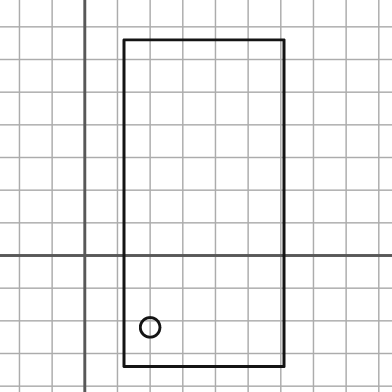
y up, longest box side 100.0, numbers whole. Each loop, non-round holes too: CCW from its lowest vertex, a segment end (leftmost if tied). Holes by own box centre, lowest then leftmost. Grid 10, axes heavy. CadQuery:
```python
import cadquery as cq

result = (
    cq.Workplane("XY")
    .moveTo(12.0, -34.0)
    .lineTo(61.0, -34.0)
    .lineTo(61.0, 66.0)
    .lineTo(12.0, 66.0)
    .close()
    .moveTo(20.0, -22.0)
    .circle(3.0)
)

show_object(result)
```